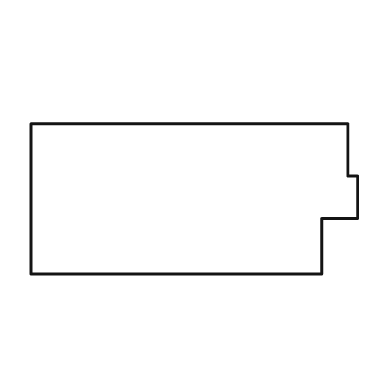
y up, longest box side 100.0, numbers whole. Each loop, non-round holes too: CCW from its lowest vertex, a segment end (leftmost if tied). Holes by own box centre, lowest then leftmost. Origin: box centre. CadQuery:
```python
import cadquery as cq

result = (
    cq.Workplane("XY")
    .moveTo(-50.0, -23.0)
    .lineTo(39.0, -23.0)
    .lineTo(39.0, -6.0)
    .lineTo(50.0, -6.0)
    .lineTo(50.0, 7.0)
    .lineTo(47.0, 7.0)
    .lineTo(47.0, 23.0)
    .lineTo(-50.0, 23.0)
    .close()
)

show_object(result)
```